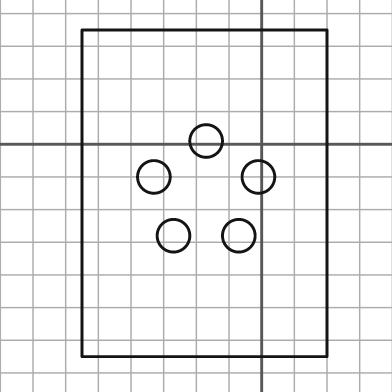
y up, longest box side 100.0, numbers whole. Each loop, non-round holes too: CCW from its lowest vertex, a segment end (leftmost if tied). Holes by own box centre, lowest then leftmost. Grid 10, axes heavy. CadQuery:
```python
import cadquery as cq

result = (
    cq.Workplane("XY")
    .moveTo(-55.0, -65.0)
    .lineTo(20.0, -65.0)
    .lineTo(20.0, 35.0)
    .lineTo(-55.0, 35.0)
    .close()
    .moveTo(-27.0, -28.0)
    .circle(5.0)
    .moveTo(-7.0, -28.0)
    .circle(5.0)
    .moveTo(-33.0, -10.0)
    .circle(5.0)
    .moveTo(-1.0, -10.0)
    .circle(5.0)
    .moveTo(-17.0, 1.0)
    .circle(5.0)
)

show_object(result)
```